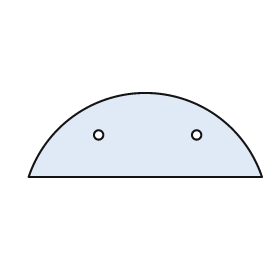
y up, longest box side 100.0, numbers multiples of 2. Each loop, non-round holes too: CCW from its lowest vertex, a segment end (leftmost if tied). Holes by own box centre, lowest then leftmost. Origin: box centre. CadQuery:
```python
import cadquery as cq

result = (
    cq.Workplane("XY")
    .moveTo(-50.0, -18.0)
    .lineTo(50.0, -18.0)
    .threePointArc((0.0, 18.0), (-50.0, -18.0))
    .close()
    .moveTo(-20.0, 0.0)
    .circle(2.0)
    .moveTo(22.0, 0.0)
    .circle(2.0)
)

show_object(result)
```